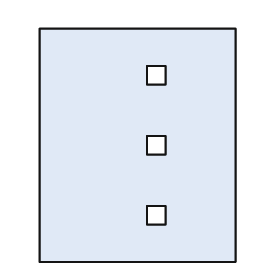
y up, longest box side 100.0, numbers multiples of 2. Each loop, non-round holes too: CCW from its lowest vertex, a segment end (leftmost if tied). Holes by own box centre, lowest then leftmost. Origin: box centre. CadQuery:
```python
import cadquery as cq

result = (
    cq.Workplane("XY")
    .moveTo(-42.0, -50.0)
    .lineTo(42.0, -50.0)
    .lineTo(42.0, 50.0)
    .lineTo(-42.0, 50.0)
    .close()
    .moveTo(4.0, -34.0)
    .lineTo(12.0, -34.0)
    .lineTo(12.0, -26.0)
    .lineTo(4.0, -26.0)
    .close()
    .moveTo(4.0, -4.0)
    .lineTo(12.0, -4.0)
    .lineTo(12.0, 4.0)
    .lineTo(4.0, 4.0)
    .close()
    .moveTo(4.0, 26.0)
    .lineTo(12.0, 26.0)
    .lineTo(12.0, 34.0)
    .lineTo(4.0, 34.0)
    .close()
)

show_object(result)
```